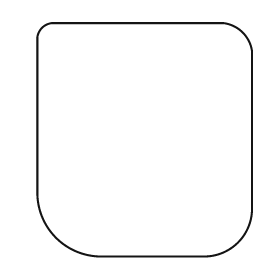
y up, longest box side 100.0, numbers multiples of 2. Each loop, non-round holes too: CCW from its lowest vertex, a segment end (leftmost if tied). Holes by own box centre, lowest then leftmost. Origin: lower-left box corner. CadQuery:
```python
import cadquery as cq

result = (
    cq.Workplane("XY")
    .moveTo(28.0, 0.0)
    .lineTo(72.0, 0.0)
    .threePointArc((86.0, 6.0), (92.0, 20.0))
    .lineTo(92.0, 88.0)
    .threePointArc((88.0, 96.0), (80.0, 100.0))
    .lineTo(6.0, 100.0)
    .threePointArc((2.0, 98.0), (0.0, 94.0))
    .lineTo(0.0, 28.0)
    .threePointArc((8.0, 8.0), (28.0, 0.0))
    .close()
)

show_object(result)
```